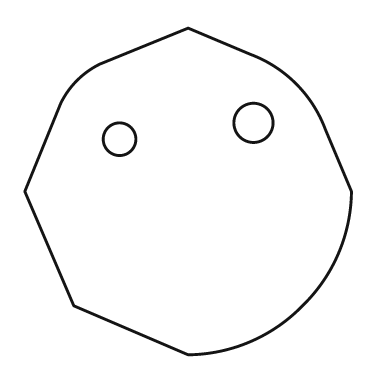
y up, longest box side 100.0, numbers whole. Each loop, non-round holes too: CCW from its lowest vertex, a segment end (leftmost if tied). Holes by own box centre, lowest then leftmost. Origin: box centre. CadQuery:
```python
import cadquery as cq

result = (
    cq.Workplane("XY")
    .moveTo(0.0, -50.0)
    .threePointArc((19.0, -46.0), (35.0, -35.0))
    .threePointArc((46.0, -19.0), (50.0, 0.0))
    .lineTo(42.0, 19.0)
    .threePointArc((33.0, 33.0), (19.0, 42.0))
    .lineTo(0.0, 50.0)
    .lineTo(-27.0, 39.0)
    .threePointArc((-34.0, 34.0), (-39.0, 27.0))
    .lineTo(-50.0, 0.0)
    .lineTo(-35.0, -35.0)
    .close()
    .moveTo(-21.0, 16.0)
    .circle(5.0)
    .moveTo(20.0, 21.0)
    .circle(6.0)
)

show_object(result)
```